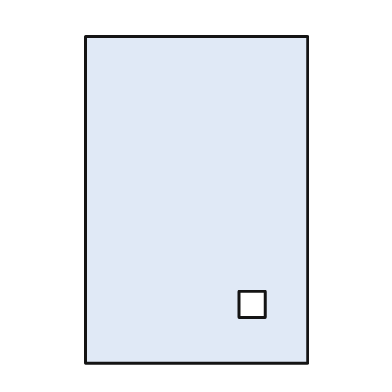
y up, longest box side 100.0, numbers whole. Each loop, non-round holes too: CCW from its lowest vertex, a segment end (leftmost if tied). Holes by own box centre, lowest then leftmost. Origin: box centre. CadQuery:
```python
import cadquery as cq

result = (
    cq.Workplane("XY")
    .moveTo(-34.0, -50.0)
    .lineTo(34.0, -50.0)
    .lineTo(34.0, 50.0)
    .lineTo(-34.0, 50.0)
    .close()
    .moveTo(13.0, -36.0)
    .lineTo(21.0, -36.0)
    .lineTo(21.0, -28.0)
    .lineTo(13.0, -28.0)
    .close()
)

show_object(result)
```